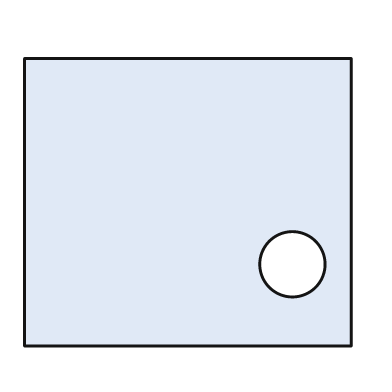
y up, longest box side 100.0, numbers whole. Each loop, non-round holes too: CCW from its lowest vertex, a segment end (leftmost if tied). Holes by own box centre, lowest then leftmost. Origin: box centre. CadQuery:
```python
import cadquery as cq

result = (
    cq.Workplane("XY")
    .moveTo(-50.0, -44.0)
    .lineTo(50.0, -44.0)
    .lineTo(50.0, 44.0)
    .lineTo(-50.0, 44.0)
    .close()
    .moveTo(32.0, -19.0)
    .circle(10.0)
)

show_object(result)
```